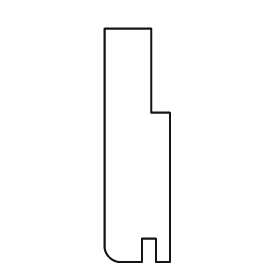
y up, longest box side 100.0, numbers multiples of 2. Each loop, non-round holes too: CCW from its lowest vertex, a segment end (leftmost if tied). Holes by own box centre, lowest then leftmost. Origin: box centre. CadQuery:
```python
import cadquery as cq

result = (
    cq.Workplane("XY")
    .moveTo(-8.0, -50.0)
    .lineTo(2.0, -50.0)
    .lineTo(2.0, -40.0)
    .lineTo(8.0, -40.0)
    .lineTo(8.0, -50.0)
    .lineTo(14.0, -50.0)
    .lineTo(14.0, 14.0)
    .lineTo(6.0, 14.0)
    .lineTo(6.0, 50.0)
    .lineTo(-14.0, 50.0)
    .lineTo(-14.0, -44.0)
    .threePointArc((-12.0, -48.0), (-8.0, -50.0))
    .close()
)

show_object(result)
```